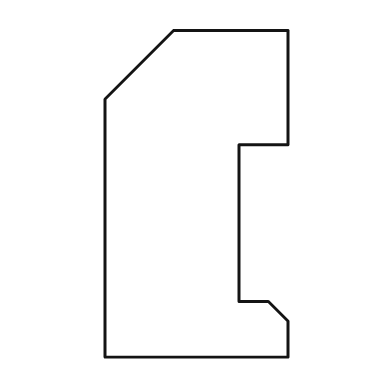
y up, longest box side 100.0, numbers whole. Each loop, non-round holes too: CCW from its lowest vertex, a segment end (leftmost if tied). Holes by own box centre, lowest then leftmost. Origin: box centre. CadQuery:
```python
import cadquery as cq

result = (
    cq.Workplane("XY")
    .moveTo(-28.0, -50.0)
    .lineTo(28.0, -50.0)
    .lineTo(28.0, -39.0)
    .lineTo(22.0, -33.0)
    .lineTo(13.0, -33.0)
    .lineTo(13.0, 15.0)
    .lineTo(28.0, 15.0)
    .lineTo(28.0, 50.0)
    .lineTo(-7.0, 50.0)
    .lineTo(-28.0, 29.0)
    .close()
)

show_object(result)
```